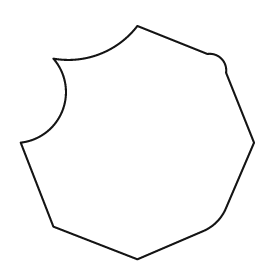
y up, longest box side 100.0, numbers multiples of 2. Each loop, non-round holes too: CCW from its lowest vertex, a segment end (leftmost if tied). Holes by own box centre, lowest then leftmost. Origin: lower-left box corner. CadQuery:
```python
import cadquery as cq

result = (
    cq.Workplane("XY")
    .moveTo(50.0, 0.0)
    .lineTo(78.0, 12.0)
    .threePointArc((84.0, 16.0), (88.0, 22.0))
    .lineTo(100.0, 50.0)
    .lineTo(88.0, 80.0)
    .threePointArc((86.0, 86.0), (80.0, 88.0))
    .lineTo(50.0, 100.0)
    .threePointArc((34.0, 88.0), (14.0, 86.0))
    .threePointArc((18.0, 64.0), (0.0, 50.0))
    .lineTo(14.0, 14.0)
    .close()
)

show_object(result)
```